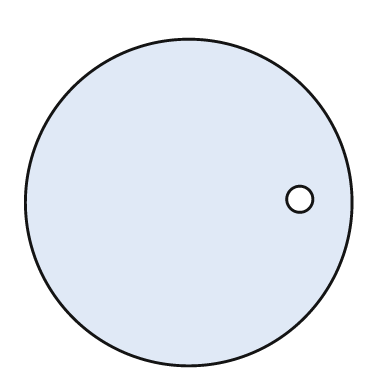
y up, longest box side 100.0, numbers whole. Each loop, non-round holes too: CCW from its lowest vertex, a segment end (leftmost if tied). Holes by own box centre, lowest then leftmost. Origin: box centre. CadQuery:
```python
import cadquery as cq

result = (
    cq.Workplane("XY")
    .moveTo(0.0, 0.0)
    .circle(50.0)
    .moveTo(34.0, 1.0)
    .circle(4.0)
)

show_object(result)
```